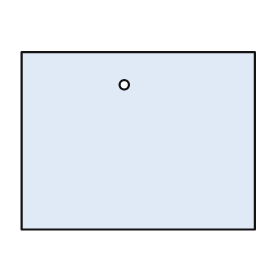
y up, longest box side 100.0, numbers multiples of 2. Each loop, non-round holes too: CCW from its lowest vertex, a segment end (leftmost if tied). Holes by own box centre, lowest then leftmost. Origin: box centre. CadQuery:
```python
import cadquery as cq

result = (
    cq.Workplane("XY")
    .moveTo(-50.0, -38.0)
    .lineTo(50.0, -38.0)
    .lineTo(50.0, 38.0)
    .lineTo(-50.0, 38.0)
    .close()
    .moveTo(-6.0, 24.0)
    .circle(2.0)
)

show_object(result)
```